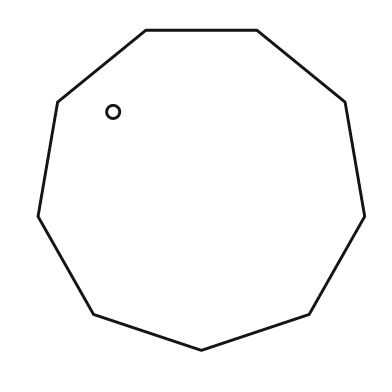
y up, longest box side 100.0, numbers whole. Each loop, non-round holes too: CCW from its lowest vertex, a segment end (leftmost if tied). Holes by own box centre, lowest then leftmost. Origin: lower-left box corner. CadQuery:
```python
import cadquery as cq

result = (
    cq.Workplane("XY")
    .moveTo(50.0, 0.0)
    .lineTo(83.0, 11.0)
    .lineTo(100.0, 41.0)
    .lineTo(94.0, 76.0)
    .lineTo(67.0, 98.0)
    .lineTo(33.0, 98.0)
    .lineTo(6.0, 76.0)
    .lineTo(0.0, 41.0)
    .lineTo(17.0, 11.0)
    .close()
    .moveTo(23.0, 73.0)
    .circle(2.0)
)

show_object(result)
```